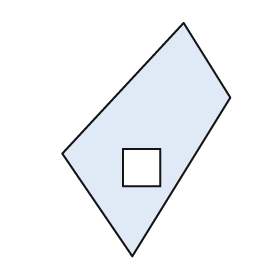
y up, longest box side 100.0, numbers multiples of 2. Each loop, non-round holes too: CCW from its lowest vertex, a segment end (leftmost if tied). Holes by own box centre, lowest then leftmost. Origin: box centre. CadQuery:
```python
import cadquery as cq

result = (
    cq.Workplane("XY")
    .moveTo(-6.0, -50.0)
    .lineTo(36.0, 18.0)
    .lineTo(16.0, 50.0)
    .lineTo(-36.0, -6.0)
    .close()
    .moveTo(-10.0, -20.0)
    .lineTo(6.0, -20.0)
    .lineTo(6.0, -4.0)
    .lineTo(-10.0, -4.0)
    .close()
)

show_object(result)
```